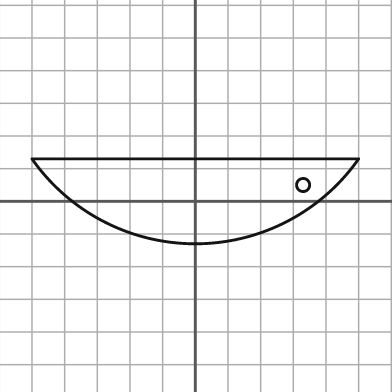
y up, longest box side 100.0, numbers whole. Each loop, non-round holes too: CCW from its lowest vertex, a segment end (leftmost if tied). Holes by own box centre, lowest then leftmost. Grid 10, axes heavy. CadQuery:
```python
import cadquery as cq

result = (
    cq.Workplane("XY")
    .moveTo(-50.0, 13.0)
    .threePointArc((0.0, -13.0), (50.0, 13.0))
    .close()
    .moveTo(33.0, 5.0)
    .circle(2.0)
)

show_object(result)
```